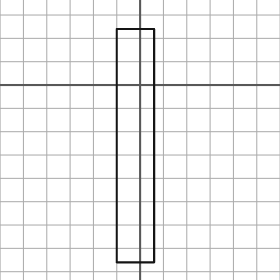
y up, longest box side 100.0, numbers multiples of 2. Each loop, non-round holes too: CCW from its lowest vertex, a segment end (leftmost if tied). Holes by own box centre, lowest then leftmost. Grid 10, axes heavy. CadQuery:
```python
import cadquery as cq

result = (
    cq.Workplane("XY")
    .moveTo(-10.0, -76.0)
    .lineTo(6.0, -76.0)
    .lineTo(6.0, 24.0)
    .lineTo(-10.0, 24.0)
    .close()
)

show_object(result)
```